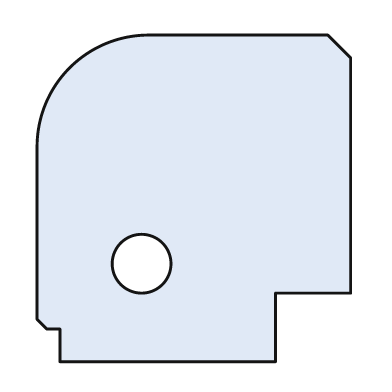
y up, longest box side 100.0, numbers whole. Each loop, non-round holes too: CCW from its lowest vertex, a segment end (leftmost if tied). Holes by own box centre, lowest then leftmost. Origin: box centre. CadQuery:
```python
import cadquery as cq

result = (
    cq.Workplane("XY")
    .moveTo(-41.0, -50.0)
    .lineTo(25.0, -50.0)
    .lineTo(25.0, -29.0)
    .lineTo(48.0, -29.0)
    .lineTo(48.0, 43.0)
    .lineTo(41.0, 50.0)
    .lineTo(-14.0, 50.0)
    .threePointArc((-38.0, 40.0), (-48.0, 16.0))
    .lineTo(-48.0, -37.0)
    .lineTo(-45.0, -40.0)
    .lineTo(-41.0, -40.0)
    .close()
    .moveTo(-16.0, -20.0)
    .circle(9.0)
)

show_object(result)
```